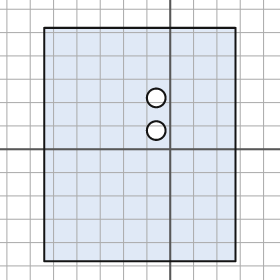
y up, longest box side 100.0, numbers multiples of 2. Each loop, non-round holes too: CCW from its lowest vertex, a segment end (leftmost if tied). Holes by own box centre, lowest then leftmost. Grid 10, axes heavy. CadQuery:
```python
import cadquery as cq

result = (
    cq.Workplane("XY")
    .moveTo(-54.0, -48.0)
    .lineTo(28.0, -48.0)
    .lineTo(28.0, 52.0)
    .lineTo(-54.0, 52.0)
    .close()
    .moveTo(-6.0, 8.0)
    .circle(4.0)
    .moveTo(-6.0, 22.0)
    .circle(4.0)
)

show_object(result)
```